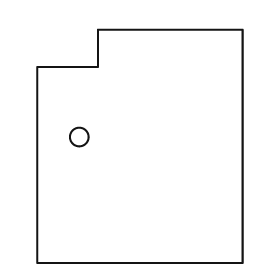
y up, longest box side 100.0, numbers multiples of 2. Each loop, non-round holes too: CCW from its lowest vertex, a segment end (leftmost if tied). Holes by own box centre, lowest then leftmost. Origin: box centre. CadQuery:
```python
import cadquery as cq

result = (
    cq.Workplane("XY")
    .moveTo(-44.0, -50.0)
    .lineTo(44.0, -50.0)
    .lineTo(44.0, 50.0)
    .lineTo(-18.0, 50.0)
    .lineTo(-18.0, 34.0)
    .lineTo(-44.0, 34.0)
    .close()
    .moveTo(-26.0, 4.0)
    .circle(4.0)
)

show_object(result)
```